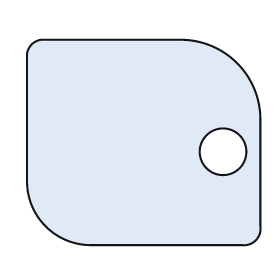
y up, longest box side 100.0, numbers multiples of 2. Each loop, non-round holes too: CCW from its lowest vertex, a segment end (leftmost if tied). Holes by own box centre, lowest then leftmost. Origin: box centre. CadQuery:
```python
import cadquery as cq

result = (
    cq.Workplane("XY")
    .moveTo(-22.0, -44.0)
    .lineTo(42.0, -44.0)
    .threePointArc((48.0, -42.0), (50.0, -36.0))
    .lineTo(50.0, 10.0)
    .threePointArc((40.0, 34.0), (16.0, 44.0))
    .lineTo(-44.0, 44.0)
    .threePointArc((-48.0, 42.0), (-50.0, 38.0))
    .lineTo(-50.0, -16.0)
    .threePointArc((-42.0, -36.0), (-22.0, -44.0))
    .close()
    .moveTo(34.0, -4.0)
    .circle(10.0)
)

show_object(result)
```